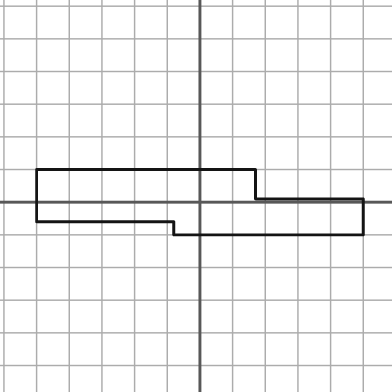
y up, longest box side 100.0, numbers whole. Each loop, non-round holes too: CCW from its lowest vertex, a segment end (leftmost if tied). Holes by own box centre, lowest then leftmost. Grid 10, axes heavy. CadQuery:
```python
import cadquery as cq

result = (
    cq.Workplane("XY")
    .moveTo(-8.0, -10.0)
    .lineTo(50.0, -10.0)
    .lineTo(50.0, 1.0)
    .lineTo(17.0, 1.0)
    .lineTo(17.0, 10.0)
    .lineTo(-50.0, 10.0)
    .lineTo(-50.0, -6.0)
    .lineTo(-8.0, -6.0)
    .close()
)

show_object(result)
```